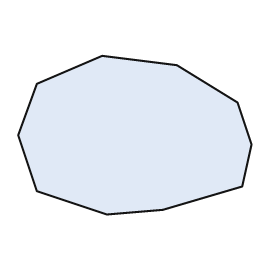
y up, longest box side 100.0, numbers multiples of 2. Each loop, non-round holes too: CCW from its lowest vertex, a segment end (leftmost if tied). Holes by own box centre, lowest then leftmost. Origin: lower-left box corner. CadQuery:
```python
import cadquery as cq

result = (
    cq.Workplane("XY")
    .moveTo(38.0, 0.0)
    .lineTo(62.0, 2.0)
    .lineTo(96.0, 12.0)
    .lineTo(100.0, 30.0)
    .lineTo(94.0, 48.0)
    .lineTo(68.0, 64.0)
    .lineTo(36.0, 68.0)
    .lineTo(8.0, 56.0)
    .lineTo(0.0, 34.0)
    .lineTo(8.0, 10.0)
    .close()
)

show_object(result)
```